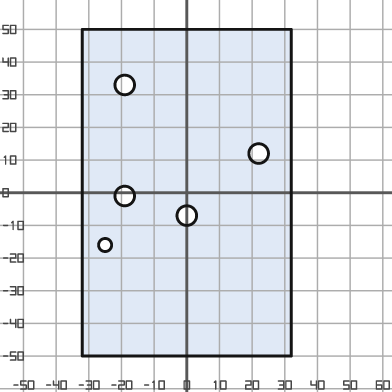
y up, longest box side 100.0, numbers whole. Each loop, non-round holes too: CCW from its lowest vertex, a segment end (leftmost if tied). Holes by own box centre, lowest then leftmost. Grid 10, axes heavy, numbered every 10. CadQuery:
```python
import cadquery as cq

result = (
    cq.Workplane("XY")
    .moveTo(-32.0, -50.0)
    .lineTo(32.0, -50.0)
    .lineTo(32.0, 50.0)
    .lineTo(-32.0, 50.0)
    .close()
    .moveTo(-25.0, -16.0)
    .circle(2.0)
    .moveTo(0.0, -7.0)
    .circle(3.0)
    .moveTo(-19.0, -1.0)
    .circle(3.0)
    .moveTo(22.0, 12.0)
    .circle(3.0)
    .moveTo(-19.0, 33.0)
    .circle(3.0)
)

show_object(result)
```